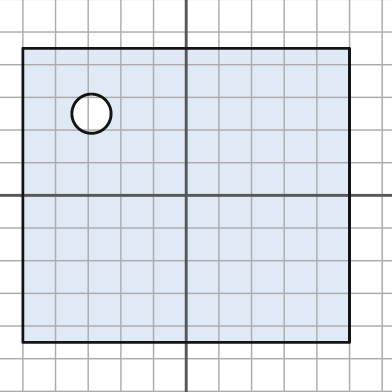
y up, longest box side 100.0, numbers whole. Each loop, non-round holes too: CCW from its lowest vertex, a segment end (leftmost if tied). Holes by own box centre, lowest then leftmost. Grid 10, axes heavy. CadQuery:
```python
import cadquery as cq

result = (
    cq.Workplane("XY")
    .moveTo(-50.0, -45.0)
    .lineTo(50.0, -45.0)
    .lineTo(50.0, 45.0)
    .lineTo(-50.0, 45.0)
    .close()
    .moveTo(-29.0, 25.0)
    .circle(6.0)
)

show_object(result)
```